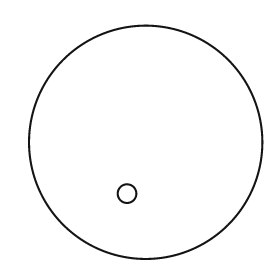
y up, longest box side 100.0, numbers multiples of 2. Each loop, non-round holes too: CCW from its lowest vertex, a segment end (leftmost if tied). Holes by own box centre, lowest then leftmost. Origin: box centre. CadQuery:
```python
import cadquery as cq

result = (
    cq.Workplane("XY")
    .moveTo(0.0, 0.0)
    .circle(50.0)
    .moveTo(-8.0, -22.0)
    .circle(4.0)
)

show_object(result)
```